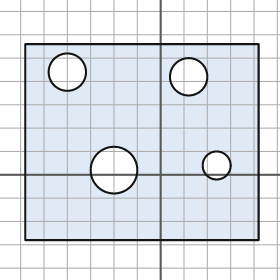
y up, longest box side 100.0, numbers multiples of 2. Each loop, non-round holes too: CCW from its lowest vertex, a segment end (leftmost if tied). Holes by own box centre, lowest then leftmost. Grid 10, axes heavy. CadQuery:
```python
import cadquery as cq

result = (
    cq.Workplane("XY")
    .moveTo(-58.0, -28.0)
    .lineTo(42.0, -28.0)
    .lineTo(42.0, 56.0)
    .lineTo(-58.0, 56.0)
    .close()
    .moveTo(-20.0, 2.0)
    .circle(10.0)
    .moveTo(24.0, 4.0)
    .circle(6.0)
    .moveTo(12.0, 42.0)
    .circle(8.0)
    .moveTo(-40.0, 44.0)
    .circle(8.0)
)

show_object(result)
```